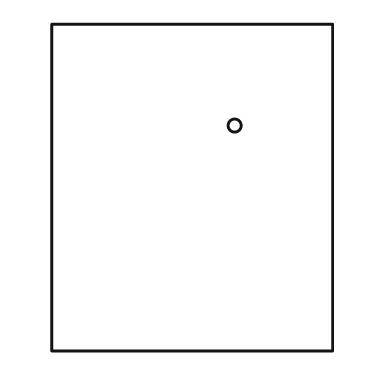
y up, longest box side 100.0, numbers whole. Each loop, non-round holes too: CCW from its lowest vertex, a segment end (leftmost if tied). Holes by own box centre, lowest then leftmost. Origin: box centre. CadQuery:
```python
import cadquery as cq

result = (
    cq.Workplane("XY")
    .moveTo(-43.0, -50.0)
    .lineTo(43.0, -50.0)
    .lineTo(43.0, 50.0)
    .lineTo(-43.0, 50.0)
    .close()
    .moveTo(13.0, 19.0)
    .circle(2.0)
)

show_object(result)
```